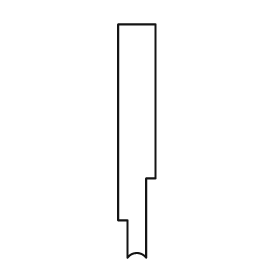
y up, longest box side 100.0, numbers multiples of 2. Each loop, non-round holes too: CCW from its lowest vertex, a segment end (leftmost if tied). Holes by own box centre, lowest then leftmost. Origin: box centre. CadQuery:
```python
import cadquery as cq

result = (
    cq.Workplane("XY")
    .moveTo(-4.0, -50.0)
    .threePointArc((0.0, -48.0), (4.0, -50.0))
    .lineTo(4.0, -16.0)
    .lineTo(8.0, -16.0)
    .lineTo(8.0, 50.0)
    .lineTo(-8.0, 50.0)
    .lineTo(-8.0, -34.0)
    .lineTo(-4.0, -34.0)
    .close()
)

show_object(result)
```